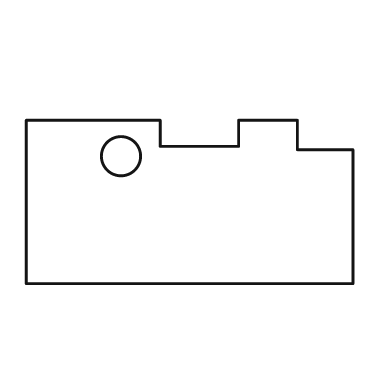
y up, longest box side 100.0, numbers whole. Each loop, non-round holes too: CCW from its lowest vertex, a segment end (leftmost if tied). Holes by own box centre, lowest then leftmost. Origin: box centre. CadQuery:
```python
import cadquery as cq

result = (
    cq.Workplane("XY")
    .moveTo(-50.0, -25.0)
    .lineTo(50.0, -25.0)
    .lineTo(50.0, 16.0)
    .lineTo(33.0, 16.0)
    .lineTo(33.0, 25.0)
    .lineTo(15.0, 25.0)
    .lineTo(15.0, 17.0)
    .lineTo(-9.0, 17.0)
    .lineTo(-9.0, 25.0)
    .lineTo(-50.0, 25.0)
    .close()
    .moveTo(-21.0, 14.0)
    .circle(6.0)
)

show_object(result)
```